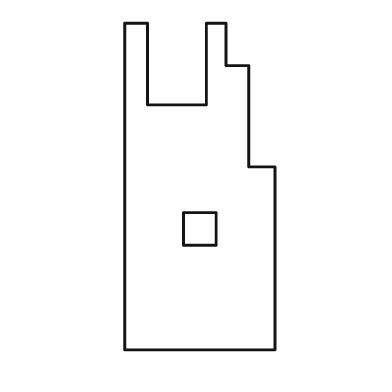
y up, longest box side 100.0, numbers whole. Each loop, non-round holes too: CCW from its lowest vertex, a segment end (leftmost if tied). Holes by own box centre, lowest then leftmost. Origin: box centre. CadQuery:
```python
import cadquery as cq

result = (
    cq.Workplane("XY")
    .moveTo(-23.0, -50.0)
    .lineTo(23.0, -50.0)
    .lineTo(23.0, 6.0)
    .lineTo(15.0, 6.0)
    .lineTo(15.0, 37.0)
    .lineTo(8.0, 37.0)
    .lineTo(8.0, 50.0)
    .lineTo(2.0, 50.0)
    .lineTo(2.0, 25.0)
    .lineTo(-16.0, 25.0)
    .lineTo(-16.0, 50.0)
    .lineTo(-23.0, 50.0)
    .close()
    .moveTo(-5.0, -18.0)
    .lineTo(5.0, -18.0)
    .lineTo(5.0, -8.0)
    .lineTo(-5.0, -8.0)
    .close()
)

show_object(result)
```